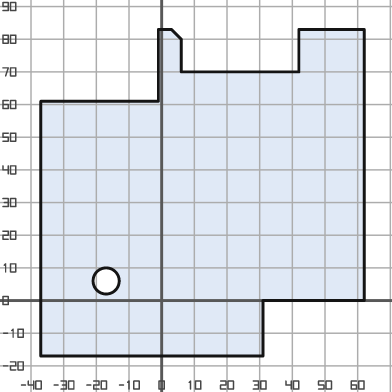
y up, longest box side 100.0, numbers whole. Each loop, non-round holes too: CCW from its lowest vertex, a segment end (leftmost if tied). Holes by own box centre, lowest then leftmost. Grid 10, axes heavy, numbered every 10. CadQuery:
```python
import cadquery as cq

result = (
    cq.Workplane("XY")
    .moveTo(-37.0, -17.0)
    .lineTo(31.0, -17.0)
    .lineTo(31.0, 0.0)
    .lineTo(62.0, 0.0)
    .lineTo(62.0, 83.0)
    .lineTo(42.0, 83.0)
    .lineTo(42.0, 70.0)
    .lineTo(6.0, 70.0)
    .lineTo(6.0, 80.0)
    .lineTo(3.0, 83.0)
    .lineTo(-1.0, 83.0)
    .lineTo(-1.0, 61.0)
    .lineTo(-37.0, 61.0)
    .close()
    .moveTo(-17.0, 6.0)
    .circle(4.0)
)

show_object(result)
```